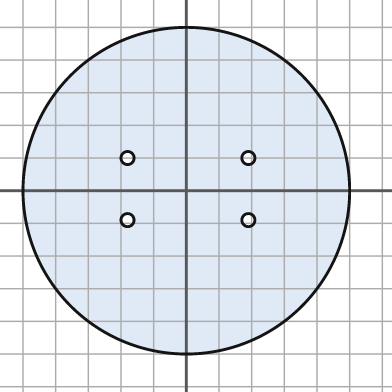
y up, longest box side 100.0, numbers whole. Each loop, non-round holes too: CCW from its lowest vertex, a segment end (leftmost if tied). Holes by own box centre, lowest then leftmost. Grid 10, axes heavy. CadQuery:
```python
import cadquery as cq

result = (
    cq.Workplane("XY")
    .moveTo(0.0, 0.0)
    .circle(50.0)
    .moveTo(-18.0, -9.0)
    .circle(2.0)
    .moveTo(19.0, -9.0)
    .circle(2.0)
    .moveTo(-18.0, 10.0)
    .circle(2.0)
    .moveTo(19.0, 10.0)
    .circle(2.0)
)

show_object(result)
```